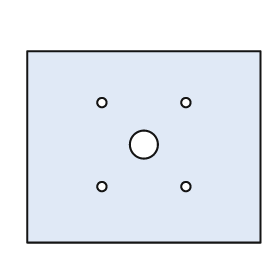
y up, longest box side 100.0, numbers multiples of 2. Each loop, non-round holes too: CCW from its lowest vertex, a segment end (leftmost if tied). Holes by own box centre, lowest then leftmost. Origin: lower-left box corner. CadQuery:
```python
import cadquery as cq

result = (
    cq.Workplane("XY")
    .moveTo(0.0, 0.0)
    .lineTo(100.0, 0.0)
    .lineTo(100.0, 82.0)
    .lineTo(0.0, 82.0)
    .close()
    .moveTo(32.0, 24.0)
    .circle(2.0)
    .moveTo(68.0, 24.0)
    .circle(2.0)
    .moveTo(50.0, 42.0)
    .circle(6.0)
    .moveTo(32.0, 60.0)
    .circle(2.0)
    .moveTo(68.0, 60.0)
    .circle(2.0)
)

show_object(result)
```